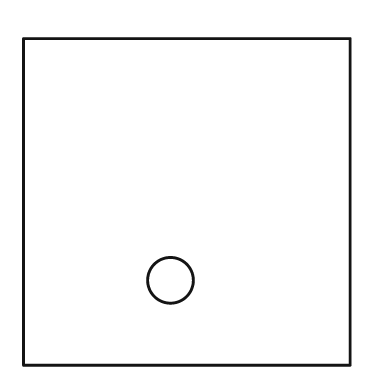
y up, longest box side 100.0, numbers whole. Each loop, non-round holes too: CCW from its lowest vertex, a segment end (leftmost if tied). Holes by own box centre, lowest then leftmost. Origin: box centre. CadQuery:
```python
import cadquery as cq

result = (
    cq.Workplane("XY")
    .moveTo(-50.0, -50.0)
    .lineTo(50.0, -50.0)
    .lineTo(50.0, 50.0)
    .lineTo(-50.0, 50.0)
    .close()
    .moveTo(-5.0, -24.0)
    .circle(7.0)
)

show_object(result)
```